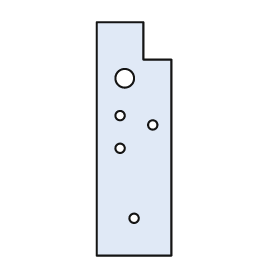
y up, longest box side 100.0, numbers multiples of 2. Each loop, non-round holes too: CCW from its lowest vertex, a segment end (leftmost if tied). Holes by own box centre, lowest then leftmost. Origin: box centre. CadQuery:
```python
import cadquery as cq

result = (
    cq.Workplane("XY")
    .moveTo(-16.0, -50.0)
    .lineTo(16.0, -50.0)
    .lineTo(16.0, 34.0)
    .lineTo(4.0, 34.0)
    .lineTo(4.0, 50.0)
    .lineTo(-16.0, 50.0)
    .close()
    .moveTo(0.0, -34.0)
    .circle(2.0)
    .moveTo(-6.0, -4.0)
    .circle(2.0)
    .moveTo(8.0, 6.0)
    .circle(2.0)
    .moveTo(-6.0, 10.0)
    .circle(2.0)
    .moveTo(-4.0, 26.0)
    .circle(4.0)
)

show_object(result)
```